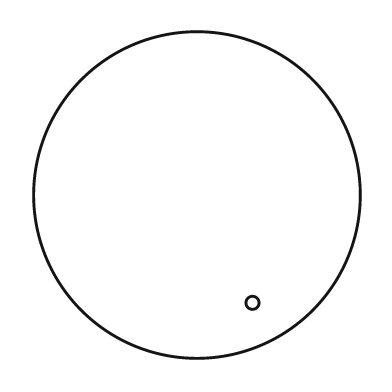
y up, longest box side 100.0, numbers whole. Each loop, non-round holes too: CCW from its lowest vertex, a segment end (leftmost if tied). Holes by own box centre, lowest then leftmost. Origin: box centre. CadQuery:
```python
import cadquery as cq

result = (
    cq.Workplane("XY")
    .moveTo(0.0, 0.0)
    .circle(50.0)
    .moveTo(17.0, -33.0)
    .circle(2.0)
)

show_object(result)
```